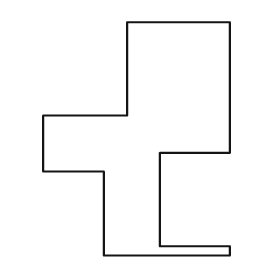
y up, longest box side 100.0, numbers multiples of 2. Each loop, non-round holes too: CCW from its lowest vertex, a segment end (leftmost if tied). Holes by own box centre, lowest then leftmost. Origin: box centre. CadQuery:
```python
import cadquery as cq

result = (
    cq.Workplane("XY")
    .moveTo(-14.0, -50.0)
    .lineTo(40.0, -50.0)
    .lineTo(40.0, -46.0)
    .lineTo(10.0, -46.0)
    .lineTo(10.0, -6.0)
    .lineTo(40.0, -6.0)
    .lineTo(40.0, 50.0)
    .lineTo(-4.0, 50.0)
    .lineTo(-4.0, 10.0)
    .lineTo(-40.0, 10.0)
    .lineTo(-40.0, -14.0)
    .lineTo(-14.0, -14.0)
    .close()
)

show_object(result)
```